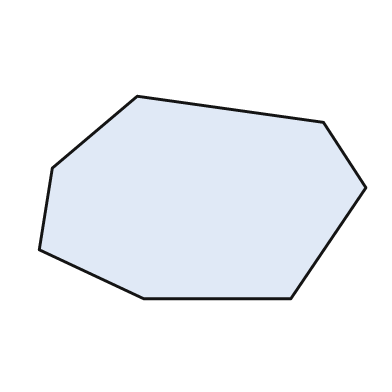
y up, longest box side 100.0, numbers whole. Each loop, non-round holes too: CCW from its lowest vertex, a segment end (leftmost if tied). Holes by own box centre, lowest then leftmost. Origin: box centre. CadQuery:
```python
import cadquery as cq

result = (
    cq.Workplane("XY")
    .moveTo(-18.0, -31.0)
    .lineTo(27.0, -31.0)
    .lineTo(50.0, 3.0)
    .lineTo(37.0, 23.0)
    .lineTo(-20.0, 31.0)
    .lineTo(-46.0, 9.0)
    .lineTo(-50.0, -16.0)
    .close()
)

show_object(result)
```